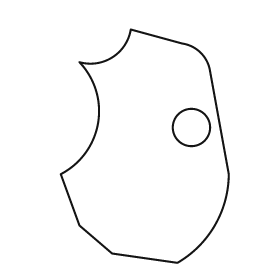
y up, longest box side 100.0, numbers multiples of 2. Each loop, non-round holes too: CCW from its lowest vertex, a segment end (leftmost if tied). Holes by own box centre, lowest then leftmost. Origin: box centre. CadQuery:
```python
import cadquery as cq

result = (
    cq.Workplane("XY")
    .moveTo(14.0, -50.0)
    .threePointArc((30.0, -34.0), (36.0, -12.0))
    .lineTo(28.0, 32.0)
    .threePointArc((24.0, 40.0), (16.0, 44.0))
    .lineTo(-6.0, 50.0)
    .threePointArc((-14.0, 38.0), (-28.0, 36.0))
    .threePointArc((-20.0, 10.0), (-36.0, -12.0))
    .lineTo(-28.0, -34.0)
    .lineTo(-14.0, -46.0)
    .close()
    .moveTo(20.0, 8.0)
    .circle(8.0)
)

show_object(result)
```